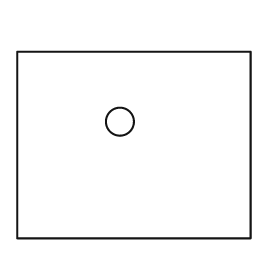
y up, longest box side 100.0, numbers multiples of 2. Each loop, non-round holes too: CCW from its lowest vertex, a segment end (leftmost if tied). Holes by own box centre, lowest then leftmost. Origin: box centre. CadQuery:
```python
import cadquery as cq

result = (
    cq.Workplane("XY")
    .moveTo(-50.0, -40.0)
    .lineTo(50.0, -40.0)
    .lineTo(50.0, 40.0)
    .lineTo(-50.0, 40.0)
    .close()
    .moveTo(-6.0, 10.0)
    .circle(6.0)
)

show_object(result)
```